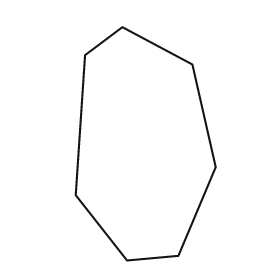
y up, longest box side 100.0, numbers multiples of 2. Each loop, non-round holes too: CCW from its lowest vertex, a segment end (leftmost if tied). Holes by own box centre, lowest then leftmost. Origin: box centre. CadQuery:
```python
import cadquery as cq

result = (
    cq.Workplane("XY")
    .moveTo(-8.0, -50.0)
    .lineTo(14.0, -48.0)
    .lineTo(30.0, -10.0)
    .lineTo(20.0, 34.0)
    .lineTo(-10.0, 50.0)
    .lineTo(-26.0, 38.0)
    .lineTo(-30.0, -22.0)
    .close()
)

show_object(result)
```